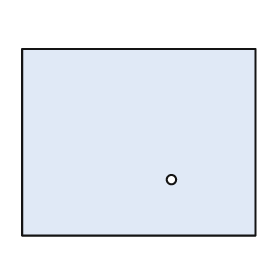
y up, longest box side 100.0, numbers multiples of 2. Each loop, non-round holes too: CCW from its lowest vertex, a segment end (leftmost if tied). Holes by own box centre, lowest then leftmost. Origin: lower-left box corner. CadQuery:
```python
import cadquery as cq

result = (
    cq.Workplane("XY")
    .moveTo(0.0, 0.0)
    .lineTo(100.0, 0.0)
    .lineTo(100.0, 80.0)
    .lineTo(0.0, 80.0)
    .close()
    .moveTo(64.0, 24.0)
    .circle(2.0)
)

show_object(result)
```